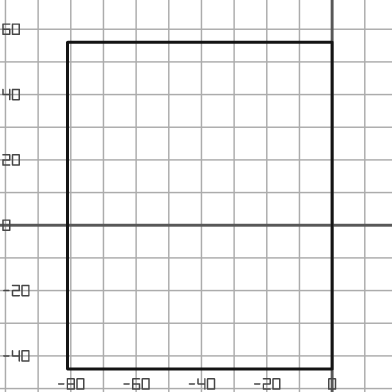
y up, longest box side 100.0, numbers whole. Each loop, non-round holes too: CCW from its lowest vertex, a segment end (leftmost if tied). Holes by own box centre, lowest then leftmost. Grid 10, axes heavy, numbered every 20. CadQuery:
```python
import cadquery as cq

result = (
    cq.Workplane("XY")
    .moveTo(-81.0, -44.0)
    .lineTo(0.0, -44.0)
    .lineTo(0.0, 56.0)
    .lineTo(-81.0, 56.0)
    .close()
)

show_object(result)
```